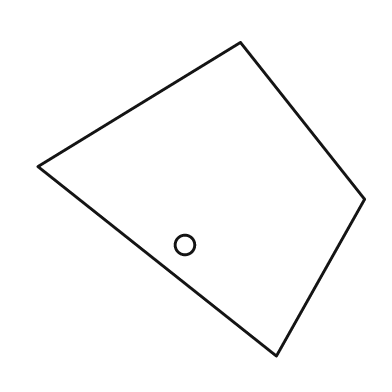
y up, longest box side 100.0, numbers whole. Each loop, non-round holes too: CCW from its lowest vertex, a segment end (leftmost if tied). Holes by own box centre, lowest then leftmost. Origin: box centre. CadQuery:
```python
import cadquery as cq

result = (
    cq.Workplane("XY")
    .moveTo(23.0, -48.0)
    .lineTo(50.0, 0.0)
    .lineTo(12.0, 48.0)
    .lineTo(-50.0, 10.0)
    .close()
    .moveTo(-5.0, -14.0)
    .circle(3.0)
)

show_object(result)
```